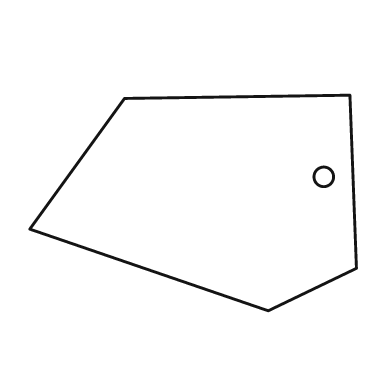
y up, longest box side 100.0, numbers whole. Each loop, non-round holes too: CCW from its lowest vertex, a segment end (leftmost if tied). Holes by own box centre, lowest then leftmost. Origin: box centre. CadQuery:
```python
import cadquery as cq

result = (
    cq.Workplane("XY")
    .moveTo(23.0, -33.0)
    .lineTo(50.0, -20.0)
    .lineTo(48.0, 33.0)
    .lineTo(-21.0, 32.0)
    .lineTo(-50.0, -8.0)
    .close()
    .moveTo(40.0, 8.0)
    .circle(3.0)
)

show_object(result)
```